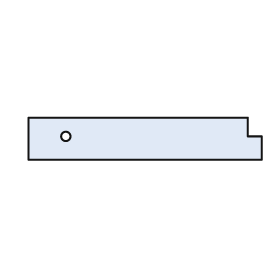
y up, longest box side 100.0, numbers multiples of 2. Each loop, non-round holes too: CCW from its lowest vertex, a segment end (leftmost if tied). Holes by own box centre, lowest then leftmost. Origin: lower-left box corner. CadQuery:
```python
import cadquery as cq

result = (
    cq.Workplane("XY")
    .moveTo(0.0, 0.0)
    .lineTo(100.0, 0.0)
    .lineTo(100.0, 10.0)
    .lineTo(94.0, 10.0)
    .lineTo(94.0, 18.0)
    .lineTo(0.0, 18.0)
    .close()
    .moveTo(16.0, 10.0)
    .circle(2.0)
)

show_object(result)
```